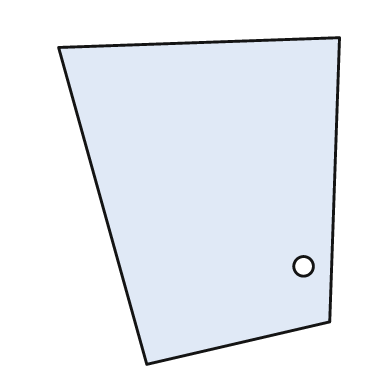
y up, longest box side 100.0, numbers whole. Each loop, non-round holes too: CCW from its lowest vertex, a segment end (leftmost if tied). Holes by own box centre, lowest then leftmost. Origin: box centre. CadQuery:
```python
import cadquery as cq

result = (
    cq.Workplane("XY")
    .moveTo(-16.0, -50.0)
    .lineTo(40.0, -37.0)
    .lineTo(43.0, 50.0)
    .lineTo(-43.0, 47.0)
    .close()
    .moveTo(32.0, -20.0)
    .circle(3.0)
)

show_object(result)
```